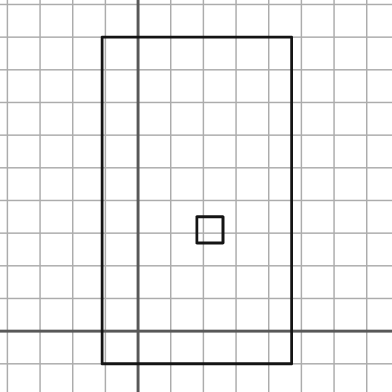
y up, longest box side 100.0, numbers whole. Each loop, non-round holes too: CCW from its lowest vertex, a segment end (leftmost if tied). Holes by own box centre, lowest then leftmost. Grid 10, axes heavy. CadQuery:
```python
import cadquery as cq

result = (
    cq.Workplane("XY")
    .moveTo(-11.0, -10.0)
    .lineTo(47.0, -10.0)
    .lineTo(47.0, 90.0)
    .lineTo(-11.0, 90.0)
    .close()
    .moveTo(18.0, 27.0)
    .lineTo(26.0, 27.0)
    .lineTo(26.0, 35.0)
    .lineTo(18.0, 35.0)
    .close()
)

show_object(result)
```